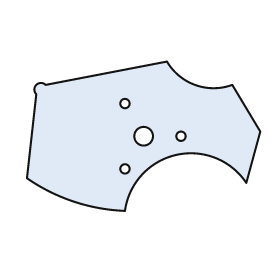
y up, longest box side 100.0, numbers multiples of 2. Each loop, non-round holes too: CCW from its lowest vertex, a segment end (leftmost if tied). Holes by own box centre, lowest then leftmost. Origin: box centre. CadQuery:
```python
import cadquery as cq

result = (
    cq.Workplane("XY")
    .moveTo(-8.0, -32.0)
    .threePointArc((14.0, -8.0), (44.0, -20.0))
    .lineTo(50.0, 2.0)
    .lineTo(38.0, 22.0)
    .threePointArc((22.0, 22.0), (10.0, 32.0))
    .lineTo(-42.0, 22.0)
    .threePointArc((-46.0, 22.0), (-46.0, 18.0))
    .lineTo(-50.0, -18.0)
    .threePointArc((-30.0, -28.0), (-8.0, -32.0))
    .close()
    .moveTo(-8.0, -14.0)
    .circle(2.0)
    .moveTo(0.0, 0.0)
    .circle(4.0)
    .moveTo(16.0, 0.0)
    .circle(2.0)
    .moveTo(-8.0, 14.0)
    .circle(2.0)
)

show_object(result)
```